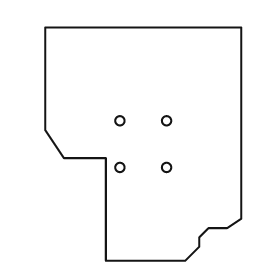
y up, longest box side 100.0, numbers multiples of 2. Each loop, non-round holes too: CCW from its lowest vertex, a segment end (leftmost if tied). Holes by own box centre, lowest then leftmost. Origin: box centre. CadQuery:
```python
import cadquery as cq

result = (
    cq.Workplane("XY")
    .moveTo(-16.0, -50.0)
    .lineTo(18.0, -50.0)
    .lineTo(24.0, -44.0)
    .lineTo(24.0, -40.0)
    .lineTo(28.0, -36.0)
    .lineTo(36.0, -36.0)
    .lineTo(42.0, -32.0)
    .lineTo(42.0, 50.0)
    .lineTo(-42.0, 50.0)
    .lineTo(-42.0, 6.0)
    .lineTo(-34.0, -6.0)
    .lineTo(-16.0, -6.0)
    .close()
    .moveTo(-10.0, -10.0)
    .circle(2.0)
    .moveTo(10.0, -10.0)
    .circle(2.0)
    .moveTo(-10.0, 10.0)
    .circle(2.0)
    .moveTo(10.0, 10.0)
    .circle(2.0)
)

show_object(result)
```